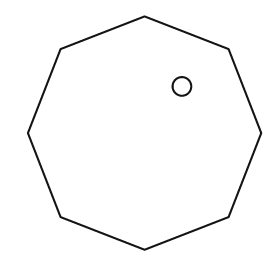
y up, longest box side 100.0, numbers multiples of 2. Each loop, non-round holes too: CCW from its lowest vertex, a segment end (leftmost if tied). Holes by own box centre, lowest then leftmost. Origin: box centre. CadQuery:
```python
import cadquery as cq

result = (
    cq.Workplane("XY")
    .moveTo(0.0, -50.0)
    .lineTo(36.0, -36.0)
    .lineTo(50.0, 0.0)
    .lineTo(36.0, 36.0)
    .lineTo(0.0, 50.0)
    .lineTo(-36.0, 36.0)
    .lineTo(-50.0, 0.0)
    .lineTo(-36.0, -36.0)
    .close()
    .moveTo(16.0, 20.0)
    .circle(4.0)
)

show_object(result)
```